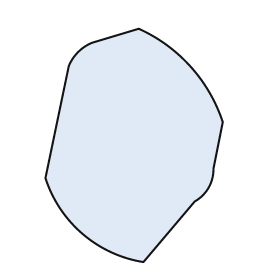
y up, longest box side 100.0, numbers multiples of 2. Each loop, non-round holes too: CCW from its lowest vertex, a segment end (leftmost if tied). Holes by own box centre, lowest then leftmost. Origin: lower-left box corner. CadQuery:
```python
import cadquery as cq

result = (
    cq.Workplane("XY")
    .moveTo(42.0, 0.0)
    .lineTo(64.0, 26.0)
    .threePointArc((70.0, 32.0), (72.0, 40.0))
    .lineTo(76.0, 60.0)
    .threePointArc((62.0, 84.0), (40.0, 100.0))
    .lineTo(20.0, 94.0)
    .threePointArc((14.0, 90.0), (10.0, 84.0))
    .lineTo(0.0, 36.0)
    .threePointArc((16.0, 12.0), (42.0, 0.0))
    .close()
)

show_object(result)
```